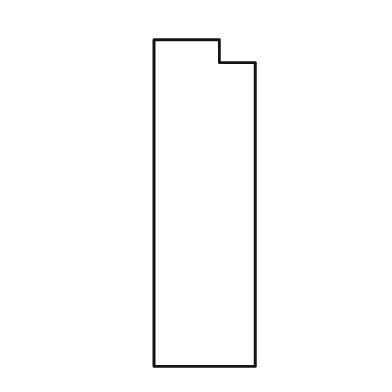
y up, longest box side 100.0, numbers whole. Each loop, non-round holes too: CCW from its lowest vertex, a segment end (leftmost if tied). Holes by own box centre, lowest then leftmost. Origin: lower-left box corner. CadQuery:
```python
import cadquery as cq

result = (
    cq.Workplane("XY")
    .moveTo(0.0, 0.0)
    .lineTo(31.0, 0.0)
    .lineTo(31.0, 93.0)
    .lineTo(20.0, 93.0)
    .lineTo(20.0, 100.0)
    .lineTo(0.0, 100.0)
    .close()
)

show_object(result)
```